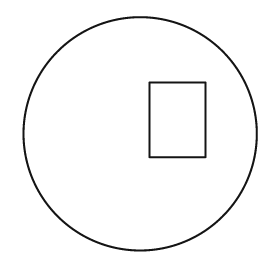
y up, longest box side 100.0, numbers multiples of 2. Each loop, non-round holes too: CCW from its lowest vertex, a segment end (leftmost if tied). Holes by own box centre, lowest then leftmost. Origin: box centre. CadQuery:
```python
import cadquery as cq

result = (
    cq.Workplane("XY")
    .moveTo(0.0, 0.0)
    .circle(50.0)
    .moveTo(4.0, -10.0)
    .lineTo(28.0, -10.0)
    .lineTo(28.0, 22.0)
    .lineTo(4.0, 22.0)
    .close()
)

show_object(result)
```